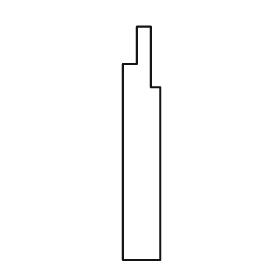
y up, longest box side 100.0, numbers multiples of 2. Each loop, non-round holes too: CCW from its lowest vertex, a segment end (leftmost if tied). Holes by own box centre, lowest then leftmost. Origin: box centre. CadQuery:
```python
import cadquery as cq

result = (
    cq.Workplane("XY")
    .moveTo(-8.0, -50.0)
    .lineTo(8.0, -50.0)
    .lineTo(8.0, 24.0)
    .lineTo(4.0, 24.0)
    .lineTo(4.0, 50.0)
    .lineTo(-2.0, 50.0)
    .lineTo(-2.0, 34.0)
    .lineTo(-8.0, 34.0)
    .close()
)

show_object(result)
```